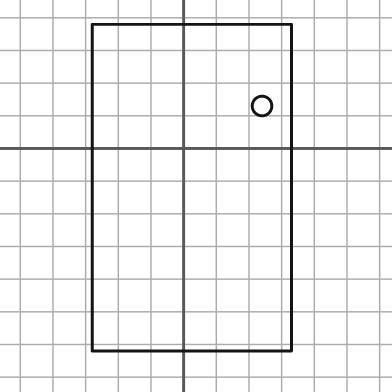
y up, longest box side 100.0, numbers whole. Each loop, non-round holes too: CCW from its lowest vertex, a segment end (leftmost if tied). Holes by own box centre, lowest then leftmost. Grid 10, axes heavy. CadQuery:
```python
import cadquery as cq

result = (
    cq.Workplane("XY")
    .moveTo(-28.0, -62.0)
    .lineTo(33.0, -62.0)
    .lineTo(33.0, 38.0)
    .lineTo(-28.0, 38.0)
    .close()
    .moveTo(24.0, 13.0)
    .circle(3.0)
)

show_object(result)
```